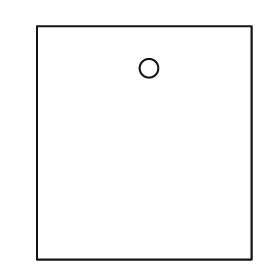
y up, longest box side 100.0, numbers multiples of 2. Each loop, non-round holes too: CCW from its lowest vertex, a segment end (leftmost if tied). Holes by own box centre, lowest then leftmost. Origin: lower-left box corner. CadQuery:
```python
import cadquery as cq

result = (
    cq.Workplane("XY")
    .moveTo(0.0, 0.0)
    .lineTo(92.0, 0.0)
    .lineTo(92.0, 100.0)
    .lineTo(0.0, 100.0)
    .close()
    .moveTo(48.0, 82.0)
    .circle(4.0)
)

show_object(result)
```